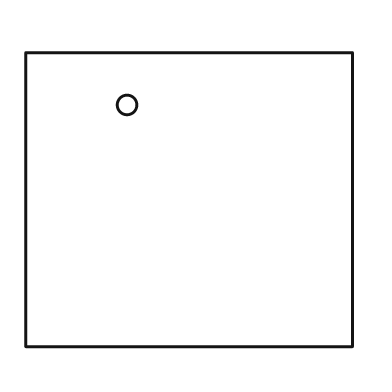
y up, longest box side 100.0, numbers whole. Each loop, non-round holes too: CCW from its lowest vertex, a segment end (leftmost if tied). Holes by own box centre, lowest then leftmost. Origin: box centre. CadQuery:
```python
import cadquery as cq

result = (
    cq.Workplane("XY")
    .moveTo(-50.0, -45.0)
    .lineTo(50.0, -45.0)
    .lineTo(50.0, 45.0)
    .lineTo(-50.0, 45.0)
    .close()
    .moveTo(-19.0, 29.0)
    .circle(3.0)
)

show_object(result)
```